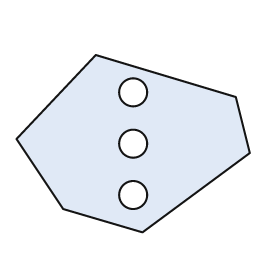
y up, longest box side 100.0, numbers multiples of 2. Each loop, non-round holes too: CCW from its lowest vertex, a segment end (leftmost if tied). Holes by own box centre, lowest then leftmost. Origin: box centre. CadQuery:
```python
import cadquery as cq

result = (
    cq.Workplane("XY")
    .moveTo(4.0, -38.0)
    .lineTo(50.0, -4.0)
    .lineTo(44.0, 20.0)
    .lineTo(-16.0, 38.0)
    .lineTo(-50.0, 2.0)
    .lineTo(-30.0, -28.0)
    .close()
    .moveTo(0.0, -22.0)
    .circle(6.0)
    .moveTo(0.0, 0.0)
    .circle(6.0)
    .moveTo(0.0, 22.0)
    .circle(6.0)
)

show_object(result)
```